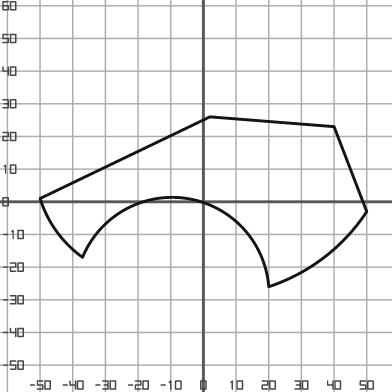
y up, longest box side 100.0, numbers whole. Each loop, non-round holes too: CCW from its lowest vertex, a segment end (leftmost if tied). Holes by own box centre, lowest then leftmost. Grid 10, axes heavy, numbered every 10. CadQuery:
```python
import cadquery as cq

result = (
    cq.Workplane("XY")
    .moveTo(20.0, -26.0)
    .threePointArc((37.0, -17.0), (50.0, -3.0))
    .lineTo(40.0, 23.0)
    .lineTo(2.0, 26.0)
    .lineTo(-50.0, 1.0)
    .threePointArc((-45.0, -9.0), (-37.0, -17.0))
    .threePointArc((-5.0, 1.0), (20.0, -26.0))
    .close()
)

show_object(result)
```